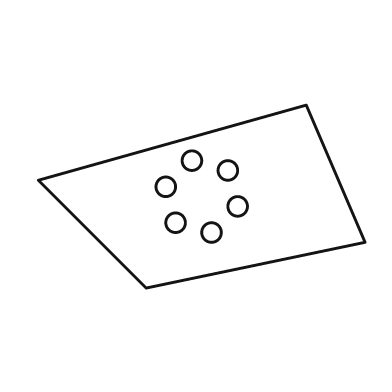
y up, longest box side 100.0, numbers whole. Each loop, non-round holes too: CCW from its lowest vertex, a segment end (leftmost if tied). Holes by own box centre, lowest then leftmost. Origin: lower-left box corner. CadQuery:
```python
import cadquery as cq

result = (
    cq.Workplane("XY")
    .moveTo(33.0, 0.0)
    .lineTo(100.0, 14.0)
    .lineTo(82.0, 56.0)
    .lineTo(0.0, 33.0)
    .close()
    .moveTo(53.0, 17.0)
    .circle(3.0)
    .moveTo(42.0, 20.0)
    .circle(3.0)
    .moveTo(61.0, 25.0)
    .circle(3.0)
    .moveTo(39.0, 31.0)
    .circle(3.0)
    .moveTo(58.0, 36.0)
    .circle(3.0)
    .moveTo(47.0, 39.0)
    .circle(3.0)
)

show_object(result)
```